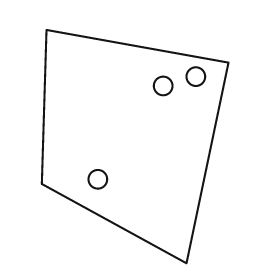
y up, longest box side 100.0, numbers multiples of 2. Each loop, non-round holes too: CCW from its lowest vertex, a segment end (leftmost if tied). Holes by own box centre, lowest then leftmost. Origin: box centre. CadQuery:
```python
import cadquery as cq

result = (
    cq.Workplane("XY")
    .moveTo(22.0, -50.0)
    .lineTo(40.0, 36.0)
    .lineTo(-38.0, 50.0)
    .lineTo(-40.0, -16.0)
    .close()
    .moveTo(-16.0, -14.0)
    .circle(4.0)
    .moveTo(12.0, 26.0)
    .circle(4.0)
    .moveTo(26.0, 30.0)
    .circle(4.0)
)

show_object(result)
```